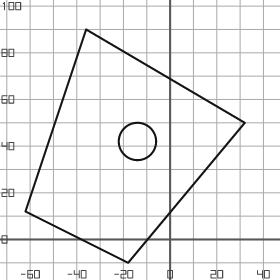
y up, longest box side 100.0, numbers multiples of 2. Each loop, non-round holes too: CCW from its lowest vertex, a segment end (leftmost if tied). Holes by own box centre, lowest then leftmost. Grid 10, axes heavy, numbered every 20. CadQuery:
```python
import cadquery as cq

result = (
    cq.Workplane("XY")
    .moveTo(-18.0, -10.0)
    .lineTo(32.0, 50.0)
    .lineTo(-36.0, 90.0)
    .lineTo(-62.0, 12.0)
    .close()
    .moveTo(-14.0, 42.0)
    .circle(8.0)
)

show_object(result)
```